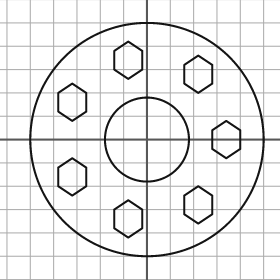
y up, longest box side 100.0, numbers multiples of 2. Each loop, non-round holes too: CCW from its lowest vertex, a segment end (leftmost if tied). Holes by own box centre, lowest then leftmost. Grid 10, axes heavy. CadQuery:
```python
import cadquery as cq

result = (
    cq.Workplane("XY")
    .moveTo(0.0, 0.0)
    .circle(50.0)
    .moveTo(-8.0, -42.0)
    .lineTo(-2.0, -38.0)
    .lineTo(-2.0, -30.0)
    .lineTo(-8.0, -26.0)
    .lineTo(-14.0, -30.0)
    .lineTo(-14.0, -38.0)
    .close()
    .moveTo(22.0, -36.0)
    .lineTo(28.0, -32.0)
    .lineTo(28.0, -24.0)
    .lineTo(22.0, -20.0)
    .lineTo(16.0, -24.0)
    .lineTo(16.0, -32.0)
    .close()
    .moveTo(-32.0, -24.0)
    .lineTo(-26.0, -20.0)
    .lineTo(-26.0, -12.0)
    .lineTo(-32.0, -8.0)
    .lineTo(-38.0, -12.0)
    .lineTo(-38.0, -20.0)
    .close()
    .moveTo(0.0, 0.0)
    .circle(18.0)
    .moveTo(34.0, -8.0)
    .lineTo(40.0, -4.0)
    .lineTo(40.0, 4.0)
    .lineTo(34.0, 8.0)
    .lineTo(28.0, 4.0)
    .lineTo(28.0, -4.0)
    .close()
    .moveTo(-32.0, 8.0)
    .lineTo(-26.0, 12.0)
    .lineTo(-26.0, 20.0)
    .lineTo(-32.0, 24.0)
    .lineTo(-38.0, 20.0)
    .lineTo(-38.0, 12.0)
    .close()
    .moveTo(22.0, 20.0)
    .lineTo(28.0, 24.0)
    .lineTo(28.0, 32.0)
    .lineTo(22.0, 36.0)
    .lineTo(16.0, 32.0)
    .lineTo(16.0, 24.0)
    .close()
    .moveTo(-8.0, 26.0)
    .lineTo(-2.0, 30.0)
    .lineTo(-2.0, 38.0)
    .lineTo(-8.0, 42.0)
    .lineTo(-14.0, 38.0)
    .lineTo(-14.0, 30.0)
    .close()
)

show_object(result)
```